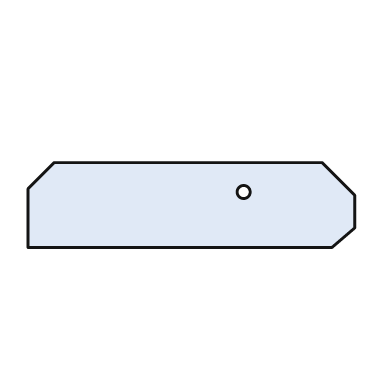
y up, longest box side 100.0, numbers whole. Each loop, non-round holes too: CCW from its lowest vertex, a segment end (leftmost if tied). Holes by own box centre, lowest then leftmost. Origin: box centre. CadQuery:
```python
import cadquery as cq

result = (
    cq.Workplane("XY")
    .moveTo(-50.0, -13.0)
    .lineTo(43.0, -13.0)
    .lineTo(50.0, -7.0)
    .lineTo(50.0, 3.0)
    .lineTo(40.0, 13.0)
    .lineTo(-42.0, 13.0)
    .lineTo(-50.0, 5.0)
    .close()
    .moveTo(16.0, 4.0)
    .circle(2.0)
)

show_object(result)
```